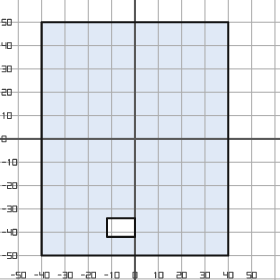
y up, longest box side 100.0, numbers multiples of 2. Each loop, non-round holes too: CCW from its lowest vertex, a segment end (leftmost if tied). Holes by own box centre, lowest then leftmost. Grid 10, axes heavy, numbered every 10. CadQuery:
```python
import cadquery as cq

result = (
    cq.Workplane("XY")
    .moveTo(-40.0, -50.0)
    .lineTo(40.0, -50.0)
    .lineTo(40.0, 50.0)
    .lineTo(-40.0, 50.0)
    .close()
    .moveTo(-12.0, -42.0)
    .lineTo(0.0, -42.0)
    .lineTo(0.0, -34.0)
    .lineTo(-12.0, -34.0)
    .close()
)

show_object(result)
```